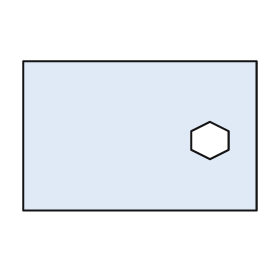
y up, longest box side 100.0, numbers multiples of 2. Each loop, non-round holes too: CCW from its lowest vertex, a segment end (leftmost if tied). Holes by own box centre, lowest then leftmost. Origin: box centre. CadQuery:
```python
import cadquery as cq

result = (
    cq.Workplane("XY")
    .moveTo(-50.0, -32.0)
    .lineTo(50.0, -32.0)
    .lineTo(50.0, 32.0)
    .lineTo(-50.0, 32.0)
    .close()
    .moveTo(30.0, -10.0)
    .lineTo(38.0, -6.0)
    .lineTo(38.0, 2.0)
    .lineTo(30.0, 6.0)
    .lineTo(22.0, 2.0)
    .lineTo(22.0, -6.0)
    .close()
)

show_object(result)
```